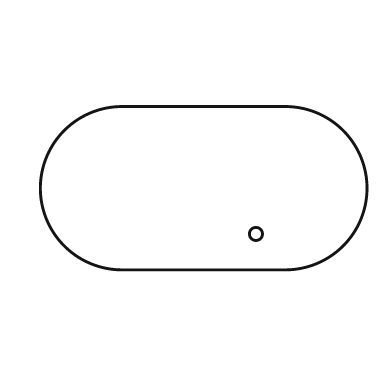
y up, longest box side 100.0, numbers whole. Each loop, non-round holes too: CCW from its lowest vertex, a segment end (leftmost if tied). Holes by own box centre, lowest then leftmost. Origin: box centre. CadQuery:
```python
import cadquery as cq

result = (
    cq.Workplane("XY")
    .moveTo(-25.0, -25.0)
    .lineTo(25.0, -25.0)
    .threePointArc((50.0, 0.0), (25.0, 25.0))
    .lineTo(-25.0, 25.0)
    .threePointArc((-50.0, 0.0), (-25.0, -25.0))
    .close()
    .moveTo(16.0, -14.0)
    .circle(2.0)
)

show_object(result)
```